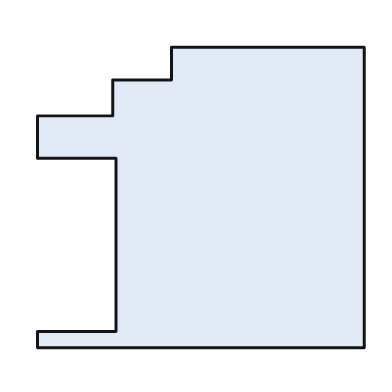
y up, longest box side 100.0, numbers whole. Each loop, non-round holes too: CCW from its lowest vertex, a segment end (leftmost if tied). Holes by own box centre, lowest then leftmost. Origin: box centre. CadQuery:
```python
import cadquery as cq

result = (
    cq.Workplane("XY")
    .moveTo(-50.0, -46.0)
    .lineTo(50.0, -46.0)
    .lineTo(50.0, 46.0)
    .lineTo(-9.0, 46.0)
    .lineTo(-9.0, 36.0)
    .lineTo(-27.0, 36.0)
    .lineTo(-27.0, 25.0)
    .lineTo(-50.0, 25.0)
    .lineTo(-50.0, 12.0)
    .lineTo(-26.0, 12.0)
    .lineTo(-26.0, -41.0)
    .lineTo(-50.0, -41.0)
    .close()
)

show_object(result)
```